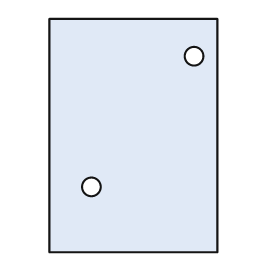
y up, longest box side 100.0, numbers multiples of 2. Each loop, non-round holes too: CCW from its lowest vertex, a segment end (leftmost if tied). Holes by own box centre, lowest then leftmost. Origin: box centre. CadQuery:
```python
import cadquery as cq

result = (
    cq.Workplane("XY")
    .moveTo(-36.0, -50.0)
    .lineTo(36.0, -50.0)
    .lineTo(36.0, 50.0)
    .lineTo(-36.0, 50.0)
    .close()
    .moveTo(-18.0, -22.0)
    .circle(4.0)
    .moveTo(26.0, 34.0)
    .circle(4.0)
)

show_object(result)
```